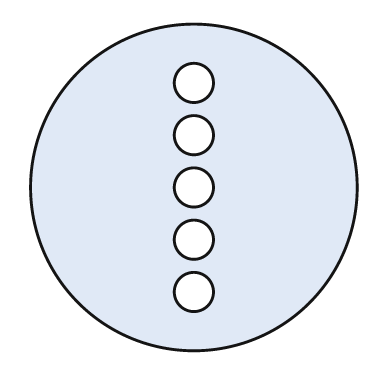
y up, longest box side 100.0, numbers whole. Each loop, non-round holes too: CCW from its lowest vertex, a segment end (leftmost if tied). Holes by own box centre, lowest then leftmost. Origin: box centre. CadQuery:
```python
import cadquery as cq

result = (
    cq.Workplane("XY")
    .moveTo(0.0, 0.0)
    .circle(50.0)
    .moveTo(0.0, -32.0)
    .circle(6.0)
    .moveTo(0.0, -16.0)
    .circle(6.0)
    .moveTo(0.0, 0.0)
    .circle(6.0)
    .moveTo(0.0, 16.0)
    .circle(6.0)
    .moveTo(0.0, 32.0)
    .circle(6.0)
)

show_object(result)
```